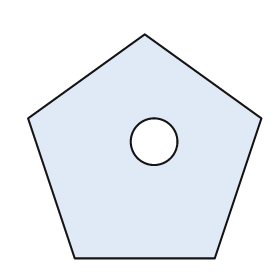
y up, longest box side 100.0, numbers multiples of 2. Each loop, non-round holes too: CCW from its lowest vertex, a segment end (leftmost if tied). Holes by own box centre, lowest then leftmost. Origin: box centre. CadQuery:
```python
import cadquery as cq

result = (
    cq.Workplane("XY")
    .moveTo(-30.0, -48.0)
    .lineTo(30.0, -48.0)
    .lineTo(50.0, 12.0)
    .lineTo(0.0, 48.0)
    .lineTo(-50.0, 12.0)
    .close()
    .moveTo(4.0, 2.0)
    .circle(10.0)
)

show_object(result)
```